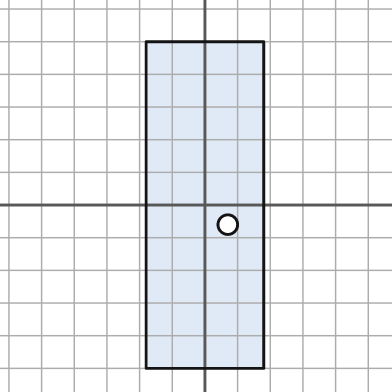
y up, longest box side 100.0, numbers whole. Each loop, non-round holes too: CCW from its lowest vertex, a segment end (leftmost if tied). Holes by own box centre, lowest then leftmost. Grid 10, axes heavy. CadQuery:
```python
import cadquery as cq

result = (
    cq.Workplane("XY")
    .moveTo(-18.0, -50.0)
    .lineTo(18.0, -50.0)
    .lineTo(18.0, 50.0)
    .lineTo(-18.0, 50.0)
    .close()
    .moveTo(7.0, -6.0)
    .circle(3.0)
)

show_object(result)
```